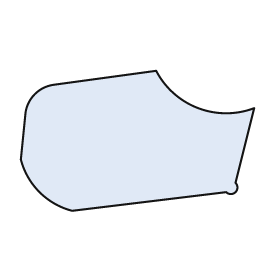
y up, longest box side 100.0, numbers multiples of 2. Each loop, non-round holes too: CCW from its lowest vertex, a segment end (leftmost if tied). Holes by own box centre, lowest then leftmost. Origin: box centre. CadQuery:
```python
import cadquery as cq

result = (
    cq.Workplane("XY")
    .moveTo(-28.0, -30.0)
    .lineTo(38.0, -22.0)
    .threePointArc((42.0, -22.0), (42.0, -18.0))
    .lineTo(50.0, 14.0)
    .threePointArc((26.0, 14.0), (8.0, 30.0))
    .lineTo(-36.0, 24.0)
    .threePointArc((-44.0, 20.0), (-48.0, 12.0))
    .lineTo(-50.0, -8.0)
    .threePointArc((-42.0, -22.0), (-28.0, -30.0))
    .close()
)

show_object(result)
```